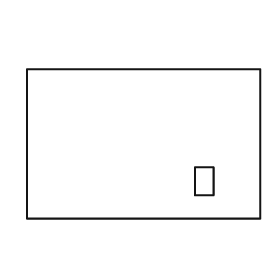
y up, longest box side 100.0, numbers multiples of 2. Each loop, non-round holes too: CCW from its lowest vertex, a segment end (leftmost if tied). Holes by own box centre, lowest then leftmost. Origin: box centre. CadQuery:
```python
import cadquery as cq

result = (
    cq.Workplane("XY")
    .moveTo(-50.0, -32.0)
    .lineTo(50.0, -32.0)
    .lineTo(50.0, 32.0)
    .lineTo(-50.0, 32.0)
    .close()
    .moveTo(22.0, -22.0)
    .lineTo(30.0, -22.0)
    .lineTo(30.0, -10.0)
    .lineTo(22.0, -10.0)
    .close()
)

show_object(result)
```